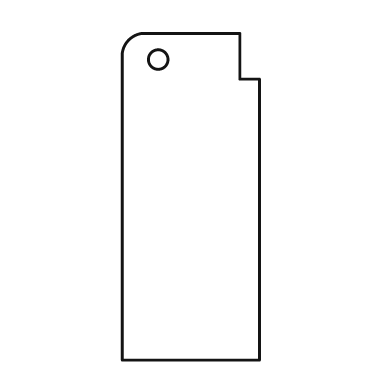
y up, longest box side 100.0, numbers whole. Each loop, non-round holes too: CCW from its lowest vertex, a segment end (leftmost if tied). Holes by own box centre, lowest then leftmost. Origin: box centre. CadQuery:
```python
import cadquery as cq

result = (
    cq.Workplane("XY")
    .moveTo(-21.0, -50.0)
    .lineTo(21.0, -50.0)
    .lineTo(21.0, 36.0)
    .lineTo(15.0, 36.0)
    .lineTo(15.0, 50.0)
    .lineTo(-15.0, 50.0)
    .threePointArc((-19.0, 48.0), (-21.0, 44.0))
    .close()
    .moveTo(-10.0, 42.0)
    .circle(3.0)
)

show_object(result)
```